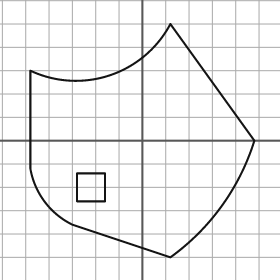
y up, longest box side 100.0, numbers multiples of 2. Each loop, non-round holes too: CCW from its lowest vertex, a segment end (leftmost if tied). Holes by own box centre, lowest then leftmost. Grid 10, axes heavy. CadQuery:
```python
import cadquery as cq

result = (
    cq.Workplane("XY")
    .moveTo(12.0, -50.0)
    .threePointArc((34.0, -28.0), (48.0, 0.0))
    .lineTo(12.0, 50.0)
    .threePointArc((-14.0, 28.0), (-48.0, 30.0))
    .lineTo(-48.0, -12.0)
    .threePointArc((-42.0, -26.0), (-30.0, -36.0))
    .close()
    .moveTo(-28.0, -26.0)
    .lineTo(-16.0, -26.0)
    .lineTo(-16.0, -14.0)
    .lineTo(-28.0, -14.0)
    .close()
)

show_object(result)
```